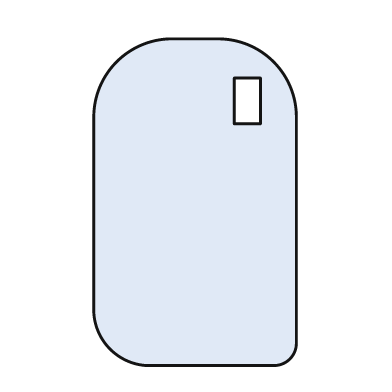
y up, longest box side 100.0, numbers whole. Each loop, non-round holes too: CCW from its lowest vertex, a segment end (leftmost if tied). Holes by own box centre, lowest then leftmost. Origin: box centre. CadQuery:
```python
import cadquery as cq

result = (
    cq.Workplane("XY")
    .moveTo(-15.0, -50.0)
    .lineTo(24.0, -50.0)
    .threePointArc((29.0, -48.0), (31.0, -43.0))
    .lineTo(31.0, 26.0)
    .threePointArc((24.0, 43.0), (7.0, 50.0))
    .lineTo(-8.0, 50.0)
    .threePointArc((-24.0, 43.0), (-31.0, 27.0))
    .lineTo(-31.0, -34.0)
    .threePointArc((-26.0, -45.0), (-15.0, -50.0))
    .close()
    .moveTo(12.0, 24.0)
    .lineTo(20.0, 24.0)
    .lineTo(20.0, 38.0)
    .lineTo(12.0, 38.0)
    .close()
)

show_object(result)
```